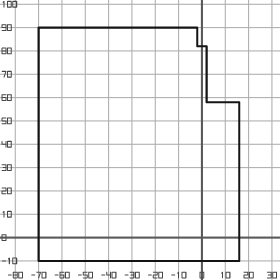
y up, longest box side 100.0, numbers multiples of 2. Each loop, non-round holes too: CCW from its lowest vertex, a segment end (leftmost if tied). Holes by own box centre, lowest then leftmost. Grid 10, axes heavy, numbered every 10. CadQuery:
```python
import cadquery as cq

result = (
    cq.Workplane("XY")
    .moveTo(-70.0, -10.0)
    .lineTo(16.0, -10.0)
    .lineTo(16.0, 58.0)
    .lineTo(2.0, 58.0)
    .lineTo(2.0, 82.0)
    .lineTo(-2.0, 82.0)
    .lineTo(-2.0, 90.0)
    .lineTo(-70.0, 90.0)
    .close()
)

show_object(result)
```